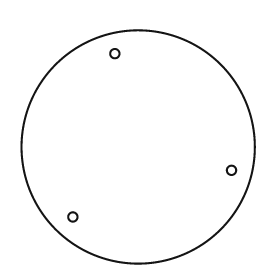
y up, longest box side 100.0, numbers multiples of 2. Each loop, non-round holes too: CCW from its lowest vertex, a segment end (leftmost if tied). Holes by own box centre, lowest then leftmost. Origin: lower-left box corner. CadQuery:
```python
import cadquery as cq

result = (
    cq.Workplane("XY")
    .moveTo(50.0, 50.0)
    .circle(50.0)
    .moveTo(22.0, 20.0)
    .circle(2.0)
    .moveTo(90.0, 40.0)
    .circle(2.0)
    .moveTo(40.0, 90.0)
    .circle(2.0)
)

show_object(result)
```